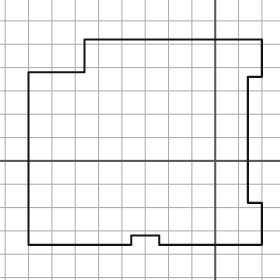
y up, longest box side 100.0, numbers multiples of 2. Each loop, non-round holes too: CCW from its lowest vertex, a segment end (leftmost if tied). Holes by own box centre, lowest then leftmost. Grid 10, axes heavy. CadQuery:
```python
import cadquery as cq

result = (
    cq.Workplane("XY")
    .moveTo(-80.0, -36.0)
    .lineTo(-36.0, -36.0)
    .lineTo(-36.0, -32.0)
    .lineTo(-24.0, -32.0)
    .lineTo(-24.0, -36.0)
    .lineTo(20.0, -36.0)
    .lineTo(20.0, -18.0)
    .lineTo(14.0, -18.0)
    .lineTo(14.0, 36.0)
    .lineTo(20.0, 36.0)
    .lineTo(20.0, 52.0)
    .lineTo(-56.0, 52.0)
    .lineTo(-56.0, 38.0)
    .lineTo(-80.0, 38.0)
    .close()
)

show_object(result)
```